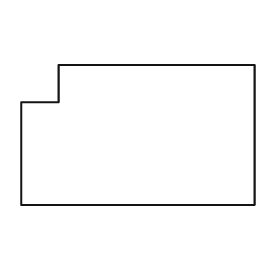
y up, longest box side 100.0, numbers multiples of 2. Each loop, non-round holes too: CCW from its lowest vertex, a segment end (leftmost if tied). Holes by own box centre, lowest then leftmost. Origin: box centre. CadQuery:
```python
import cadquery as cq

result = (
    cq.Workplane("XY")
    .moveTo(-50.0, -30.0)
    .lineTo(50.0, -30.0)
    .lineTo(50.0, 30.0)
    .lineTo(-34.0, 30.0)
    .lineTo(-34.0, 14.0)
    .lineTo(-50.0, 14.0)
    .close()
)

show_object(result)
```